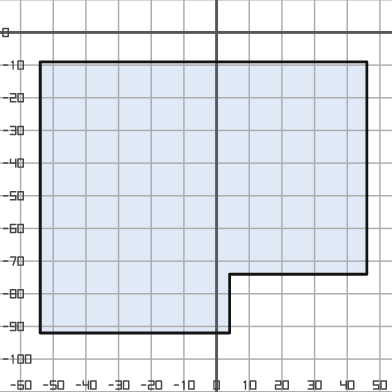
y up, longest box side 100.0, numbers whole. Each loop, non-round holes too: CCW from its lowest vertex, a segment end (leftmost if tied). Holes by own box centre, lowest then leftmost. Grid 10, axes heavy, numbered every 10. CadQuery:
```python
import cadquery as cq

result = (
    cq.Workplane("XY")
    .moveTo(-54.0, -92.0)
    .lineTo(4.0, -92.0)
    .lineTo(4.0, -74.0)
    .lineTo(46.0, -74.0)
    .lineTo(46.0, -9.0)
    .lineTo(-54.0, -9.0)
    .close()
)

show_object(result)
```